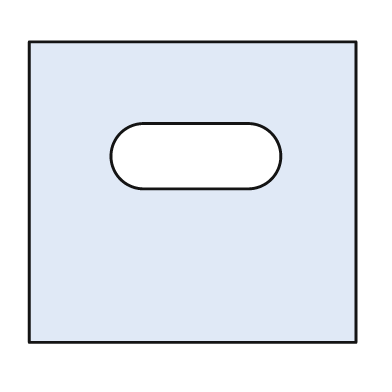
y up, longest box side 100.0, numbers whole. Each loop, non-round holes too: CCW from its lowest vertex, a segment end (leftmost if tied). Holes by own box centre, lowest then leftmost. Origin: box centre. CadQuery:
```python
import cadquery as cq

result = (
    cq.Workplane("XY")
    .moveTo(-50.0, -46.0)
    .lineTo(50.0, -46.0)
    .lineTo(50.0, 46.0)
    .lineTo(-50.0, 46.0)
    .close()
    .moveTo(-15.0, 1.0)
    .lineTo(17.0, 1.0)
    .threePointArc((27.0, 11.0), (17.0, 21.0))
    .lineTo(-15.0, 21.0)
    .threePointArc((-25.0, 11.0), (-15.0, 1.0))
    .close()
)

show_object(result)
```